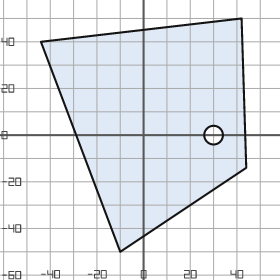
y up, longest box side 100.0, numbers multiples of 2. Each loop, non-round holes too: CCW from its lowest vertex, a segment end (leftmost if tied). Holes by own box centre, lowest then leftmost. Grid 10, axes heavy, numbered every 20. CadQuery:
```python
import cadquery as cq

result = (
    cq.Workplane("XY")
    .moveTo(-10.0, -50.0)
    .lineTo(44.0, -14.0)
    .lineTo(42.0, 50.0)
    .lineTo(-44.0, 40.0)
    .close()
    .moveTo(30.0, 0.0)
    .circle(4.0)
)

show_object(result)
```